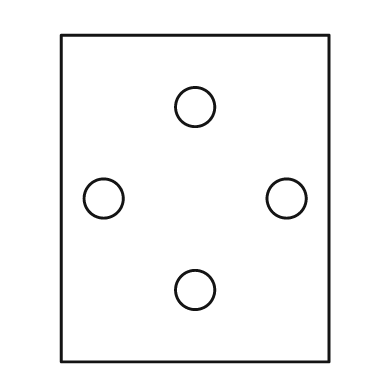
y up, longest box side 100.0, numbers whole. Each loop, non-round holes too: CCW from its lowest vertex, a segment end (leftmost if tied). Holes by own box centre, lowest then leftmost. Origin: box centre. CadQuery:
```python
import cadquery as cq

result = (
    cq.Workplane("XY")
    .moveTo(-41.0, -50.0)
    .lineTo(41.0, -50.0)
    .lineTo(41.0, 50.0)
    .lineTo(-41.0, 50.0)
    .close()
    .moveTo(0.0, -28.0)
    .circle(6.0)
    .moveTo(-28.0, 0.0)
    .circle(6.0)
    .moveTo(28.0, 0.0)
    .circle(6.0)
    .moveTo(0.0, 28.0)
    .circle(6.0)
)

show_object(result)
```